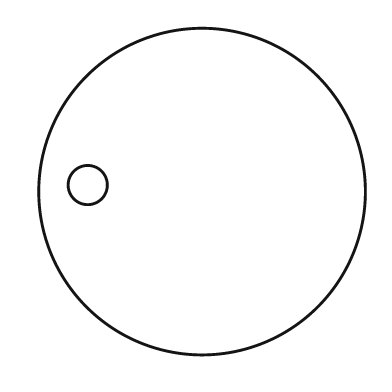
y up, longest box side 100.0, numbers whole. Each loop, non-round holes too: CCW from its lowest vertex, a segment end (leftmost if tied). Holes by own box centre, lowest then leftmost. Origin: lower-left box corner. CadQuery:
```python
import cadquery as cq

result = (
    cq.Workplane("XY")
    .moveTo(50.0, 50.0)
    .circle(50.0)
    .moveTo(15.0, 52.0)
    .circle(6.0)
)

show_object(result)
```